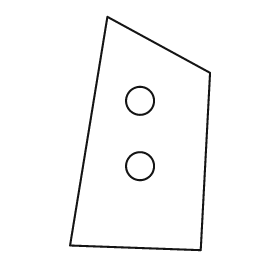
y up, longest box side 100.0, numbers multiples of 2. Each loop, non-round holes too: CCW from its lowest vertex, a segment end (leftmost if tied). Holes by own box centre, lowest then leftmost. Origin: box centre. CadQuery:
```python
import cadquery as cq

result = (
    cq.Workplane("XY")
    .moveTo(26.0, -50.0)
    .lineTo(30.0, 26.0)
    .lineTo(-14.0, 50.0)
    .lineTo(-30.0, -48.0)
    .close()
    .moveTo(0.0, -14.0)
    .circle(6.0)
    .moveTo(0.0, 14.0)
    .circle(6.0)
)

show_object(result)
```